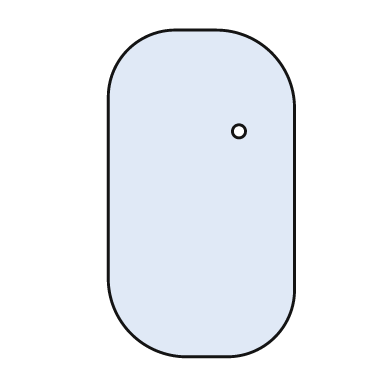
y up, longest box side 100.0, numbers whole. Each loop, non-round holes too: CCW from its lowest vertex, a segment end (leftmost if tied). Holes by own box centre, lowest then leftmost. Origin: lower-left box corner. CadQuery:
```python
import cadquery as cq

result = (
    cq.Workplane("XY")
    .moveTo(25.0, 0.0)
    .lineTo(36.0, 0.0)
    .threePointArc((51.0, 6.0), (57.0, 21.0))
    .lineTo(57.0, 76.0)
    .threePointArc((50.0, 93.0), (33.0, 100.0))
    .lineTo(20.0, 100.0)
    .threePointArc((6.0, 94.0), (0.0, 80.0))
    .lineTo(0.0, 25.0)
    .threePointArc((7.0, 7.0), (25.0, 0.0))
    .close()
    .moveTo(40.0, 69.0)
    .circle(2.0)
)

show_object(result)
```